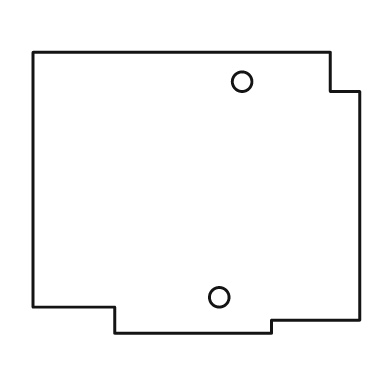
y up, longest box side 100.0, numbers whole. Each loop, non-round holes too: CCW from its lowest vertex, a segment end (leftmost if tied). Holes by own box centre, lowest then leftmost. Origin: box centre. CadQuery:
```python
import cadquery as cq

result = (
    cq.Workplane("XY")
    .moveTo(-25.0, -43.0)
    .lineTo(23.0, -43.0)
    .lineTo(23.0, -39.0)
    .lineTo(50.0, -39.0)
    .lineTo(50.0, 31.0)
    .lineTo(41.0, 31.0)
    .lineTo(41.0, 43.0)
    .lineTo(-50.0, 43.0)
    .lineTo(-50.0, -35.0)
    .lineTo(-25.0, -35.0)
    .close()
    .moveTo(7.0, -32.0)
    .circle(3.0)
    .moveTo(14.0, 34.0)
    .circle(3.0)
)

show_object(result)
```